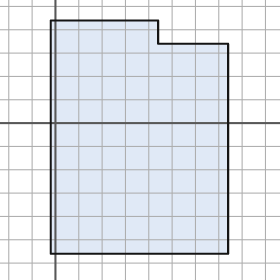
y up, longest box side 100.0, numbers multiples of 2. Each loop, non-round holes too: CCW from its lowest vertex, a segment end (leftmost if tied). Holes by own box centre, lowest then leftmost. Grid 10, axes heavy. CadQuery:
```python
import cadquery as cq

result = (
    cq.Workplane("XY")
    .moveTo(-2.0, -56.0)
    .lineTo(74.0, -56.0)
    .lineTo(74.0, 34.0)
    .lineTo(44.0, 34.0)
    .lineTo(44.0, 44.0)
    .lineTo(-2.0, 44.0)
    .close()
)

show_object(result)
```